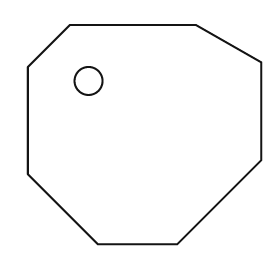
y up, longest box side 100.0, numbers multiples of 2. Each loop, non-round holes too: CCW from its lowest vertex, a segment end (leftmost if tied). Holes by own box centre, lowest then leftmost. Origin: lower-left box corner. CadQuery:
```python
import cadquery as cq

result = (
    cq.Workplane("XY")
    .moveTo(30.0, 0.0)
    .lineTo(64.0, 0.0)
    .lineTo(100.0, 36.0)
    .lineTo(100.0, 78.0)
    .lineTo(72.0, 94.0)
    .lineTo(18.0, 94.0)
    .lineTo(0.0, 76.0)
    .lineTo(0.0, 30.0)
    .close()
    .moveTo(26.0, 70.0)
    .circle(6.0)
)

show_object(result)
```